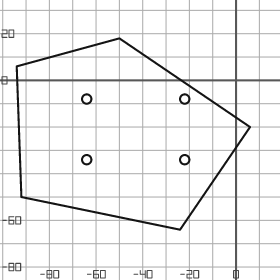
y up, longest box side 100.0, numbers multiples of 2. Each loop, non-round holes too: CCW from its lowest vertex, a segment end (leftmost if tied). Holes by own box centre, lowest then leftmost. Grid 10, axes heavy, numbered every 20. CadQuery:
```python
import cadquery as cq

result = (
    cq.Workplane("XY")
    .moveTo(-24.0, -64.0)
    .lineTo(6.0, -20.0)
    .lineTo(-50.0, 18.0)
    .lineTo(-94.0, 6.0)
    .lineTo(-92.0, -50.0)
    .close()
    .moveTo(-64.0, -34.0)
    .circle(2.0)
    .moveTo(-22.0, -34.0)
    .circle(2.0)
    .moveTo(-64.0, -8.0)
    .circle(2.0)
    .moveTo(-22.0, -8.0)
    .circle(2.0)
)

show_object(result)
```